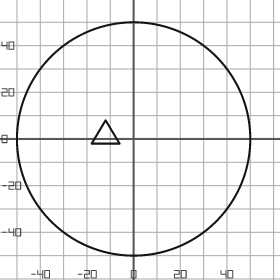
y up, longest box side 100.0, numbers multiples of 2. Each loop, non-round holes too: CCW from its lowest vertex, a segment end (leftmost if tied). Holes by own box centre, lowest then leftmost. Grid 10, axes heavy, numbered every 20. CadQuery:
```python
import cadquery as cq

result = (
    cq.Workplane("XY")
    .moveTo(0.0, 0.0)
    .circle(50.0)
    .moveTo(-18.0, -2.0)
    .lineTo(-6.0, -2.0)
    .lineTo(-12.0, 8.0)
    .close()
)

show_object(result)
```